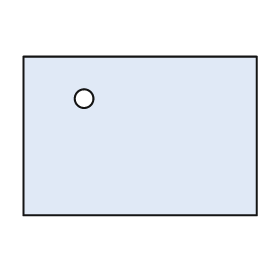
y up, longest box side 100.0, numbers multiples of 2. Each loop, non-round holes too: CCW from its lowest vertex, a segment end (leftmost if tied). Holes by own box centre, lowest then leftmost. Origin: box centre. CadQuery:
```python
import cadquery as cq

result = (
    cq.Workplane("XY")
    .moveTo(-50.0, -34.0)
    .lineTo(50.0, -34.0)
    .lineTo(50.0, 34.0)
    .lineTo(-50.0, 34.0)
    .close()
    .moveTo(-24.0, 16.0)
    .circle(4.0)
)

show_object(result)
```